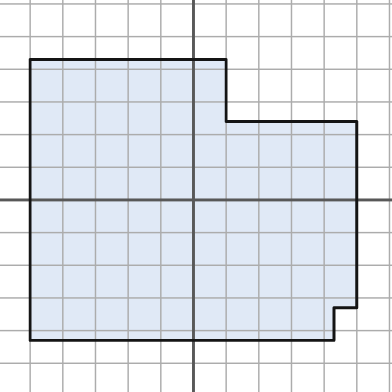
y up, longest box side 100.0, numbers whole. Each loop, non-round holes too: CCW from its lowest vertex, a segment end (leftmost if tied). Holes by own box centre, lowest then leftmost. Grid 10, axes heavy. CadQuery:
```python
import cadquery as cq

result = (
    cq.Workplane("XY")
    .moveTo(-50.0, -43.0)
    .lineTo(43.0, -43.0)
    .lineTo(43.0, -33.0)
    .lineTo(50.0, -33.0)
    .lineTo(50.0, 24.0)
    .lineTo(10.0, 24.0)
    .lineTo(10.0, 43.0)
    .lineTo(-50.0, 43.0)
    .close()
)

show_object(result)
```